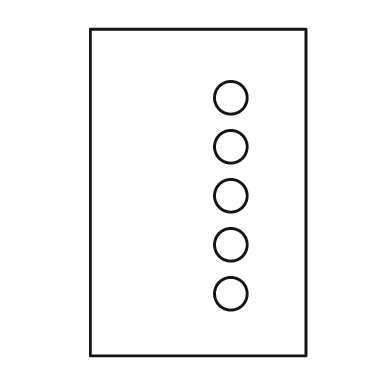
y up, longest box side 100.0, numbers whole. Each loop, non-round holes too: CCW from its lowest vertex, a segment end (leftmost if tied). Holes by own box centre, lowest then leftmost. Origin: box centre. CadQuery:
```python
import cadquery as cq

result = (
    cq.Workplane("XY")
    .moveTo(-33.0, -50.0)
    .lineTo(33.0, -50.0)
    .lineTo(33.0, 50.0)
    .lineTo(-33.0, 50.0)
    .close()
    .moveTo(10.0, -31.0)
    .circle(5.0)
    .moveTo(10.0, -16.0)
    .circle(5.0)
    .moveTo(10.0, -1.0)
    .circle(5.0)
    .moveTo(10.0, 14.0)
    .circle(5.0)
    .moveTo(10.0, 29.0)
    .circle(5.0)
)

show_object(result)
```